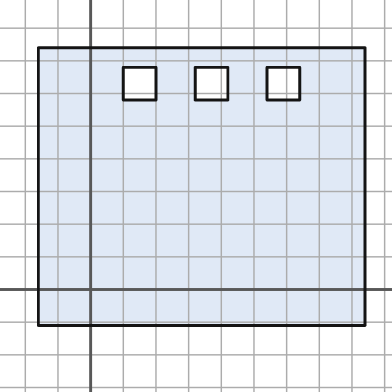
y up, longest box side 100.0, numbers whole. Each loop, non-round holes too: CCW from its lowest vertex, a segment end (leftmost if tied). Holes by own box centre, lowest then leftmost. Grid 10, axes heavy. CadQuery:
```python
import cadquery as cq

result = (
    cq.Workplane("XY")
    .moveTo(-16.0, -11.0)
    .lineTo(84.0, -11.0)
    .lineTo(84.0, 74.0)
    .lineTo(-16.0, 74.0)
    .close()
    .moveTo(10.0, 58.0)
    .lineTo(20.0, 58.0)
    .lineTo(20.0, 68.0)
    .lineTo(10.0, 68.0)
    .close()
    .moveTo(32.0, 58.0)
    .lineTo(42.0, 58.0)
    .lineTo(42.0, 68.0)
    .lineTo(32.0, 68.0)
    .close()
    .moveTo(54.0, 58.0)
    .lineTo(64.0, 58.0)
    .lineTo(64.0, 68.0)
    .lineTo(54.0, 68.0)
    .close()
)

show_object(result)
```